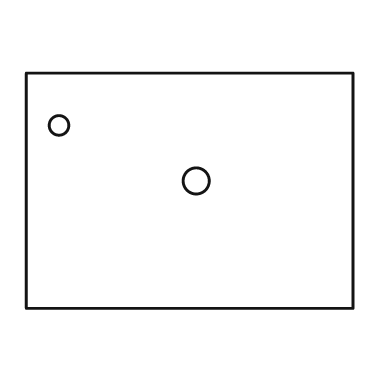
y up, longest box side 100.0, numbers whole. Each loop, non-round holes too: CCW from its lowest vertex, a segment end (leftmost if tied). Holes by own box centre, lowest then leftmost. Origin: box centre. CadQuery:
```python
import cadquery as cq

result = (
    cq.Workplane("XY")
    .moveTo(-50.0, -36.0)
    .lineTo(50.0, -36.0)
    .lineTo(50.0, 36.0)
    .lineTo(-50.0, 36.0)
    .close()
    .moveTo(2.0, 3.0)
    .circle(4.0)
    .moveTo(-40.0, 20.0)
    .circle(3.0)
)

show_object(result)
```